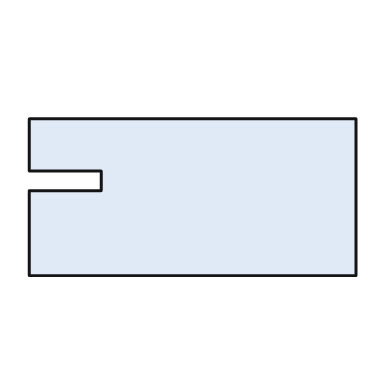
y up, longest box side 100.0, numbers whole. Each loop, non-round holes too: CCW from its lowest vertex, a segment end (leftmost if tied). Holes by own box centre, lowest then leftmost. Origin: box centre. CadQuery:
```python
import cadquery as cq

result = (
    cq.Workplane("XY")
    .moveTo(-50.0, -24.0)
    .lineTo(50.0, -24.0)
    .lineTo(50.0, 24.0)
    .lineTo(-50.0, 24.0)
    .lineTo(-50.0, 8.0)
    .lineTo(-28.0, 8.0)
    .lineTo(-28.0, 2.0)
    .lineTo(-50.0, 2.0)
    .close()
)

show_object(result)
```